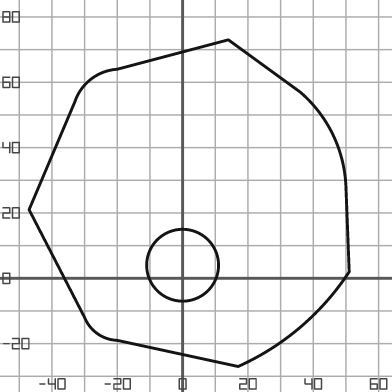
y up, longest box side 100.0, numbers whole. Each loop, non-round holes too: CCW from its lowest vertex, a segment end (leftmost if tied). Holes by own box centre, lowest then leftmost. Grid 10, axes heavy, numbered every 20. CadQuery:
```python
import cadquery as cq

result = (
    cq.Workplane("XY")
    .moveTo(17.0, -27.0)
    .threePointArc((36.0, -15.0), (51.0, 2.0))
    .lineTo(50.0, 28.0)
    .threePointArc((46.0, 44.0), (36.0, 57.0))
    .lineTo(14.0, 73.0)
    .lineTo(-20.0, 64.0)
    .threePointArc((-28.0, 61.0), (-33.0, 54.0))
    .lineTo(-47.0, 21.0)
    .lineTo(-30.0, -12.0)
    .threePointArc((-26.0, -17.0), (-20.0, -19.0))
    .close()
    .moveTo(0.0, 4.0)
    .circle(11.0)
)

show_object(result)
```